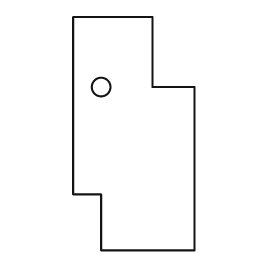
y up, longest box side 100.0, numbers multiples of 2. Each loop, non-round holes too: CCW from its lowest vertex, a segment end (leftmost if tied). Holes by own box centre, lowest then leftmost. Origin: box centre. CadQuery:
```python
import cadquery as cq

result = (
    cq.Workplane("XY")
    .moveTo(-14.0, -50.0)
    .lineTo(26.0, -50.0)
    .lineTo(26.0, 20.0)
    .lineTo(8.0, 20.0)
    .lineTo(8.0, 50.0)
    .lineTo(-26.0, 50.0)
    .lineTo(-26.0, -26.0)
    .lineTo(-14.0, -26.0)
    .close()
    .moveTo(-14.0, 20.0)
    .circle(4.0)
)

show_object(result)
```